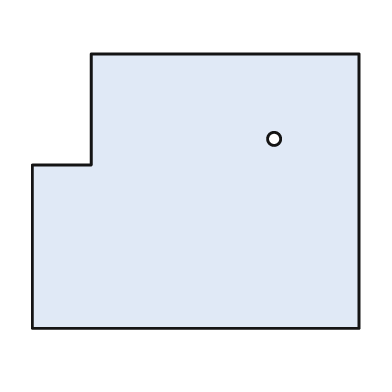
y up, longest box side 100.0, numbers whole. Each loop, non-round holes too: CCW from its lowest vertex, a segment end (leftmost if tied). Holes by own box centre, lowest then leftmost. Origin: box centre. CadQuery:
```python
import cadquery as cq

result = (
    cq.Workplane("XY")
    .moveTo(-50.0, -42.0)
    .lineTo(50.0, -42.0)
    .lineTo(50.0, 42.0)
    .lineTo(-32.0, 42.0)
    .lineTo(-32.0, 8.0)
    .lineTo(-50.0, 8.0)
    .close()
    .moveTo(24.0, 16.0)
    .circle(2.0)
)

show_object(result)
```